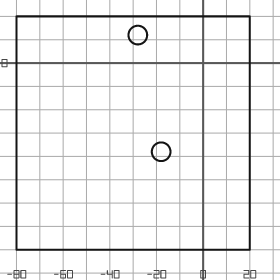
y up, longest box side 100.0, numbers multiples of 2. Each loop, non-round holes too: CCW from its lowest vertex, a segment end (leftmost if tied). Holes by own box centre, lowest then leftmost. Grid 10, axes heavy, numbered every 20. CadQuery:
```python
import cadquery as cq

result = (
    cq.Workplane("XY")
    .moveTo(-80.0, -80.0)
    .lineTo(20.0, -80.0)
    .lineTo(20.0, 20.0)
    .lineTo(-80.0, 20.0)
    .close()
    .moveTo(-18.0, -38.0)
    .circle(4.0)
    .moveTo(-28.0, 12.0)
    .circle(4.0)
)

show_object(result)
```